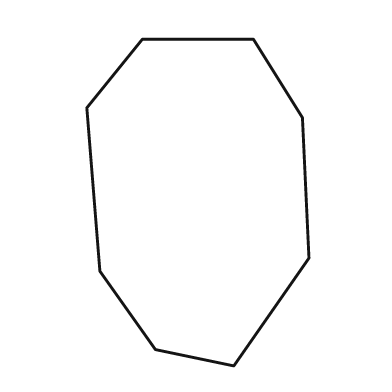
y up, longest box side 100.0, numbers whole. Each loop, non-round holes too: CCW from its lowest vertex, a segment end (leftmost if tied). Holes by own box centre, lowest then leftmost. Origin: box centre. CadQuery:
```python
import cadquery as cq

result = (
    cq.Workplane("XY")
    .moveTo(11.0, -50.0)
    .lineTo(34.0, -17.0)
    .lineTo(32.0, 26.0)
    .lineTo(17.0, 50.0)
    .lineTo(-17.0, 50.0)
    .lineTo(-34.0, 29.0)
    .lineTo(-30.0, -21.0)
    .lineTo(-13.0, -45.0)
    .close()
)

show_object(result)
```